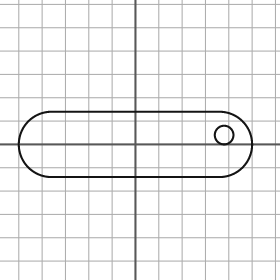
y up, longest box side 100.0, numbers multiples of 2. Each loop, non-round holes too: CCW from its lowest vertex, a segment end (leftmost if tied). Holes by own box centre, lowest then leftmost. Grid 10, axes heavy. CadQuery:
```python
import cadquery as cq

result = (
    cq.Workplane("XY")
    .moveTo(-36.0, -14.0)
    .lineTo(36.0, -14.0)
    .threePointArc((50.0, 0.0), (36.0, 14.0))
    .lineTo(-36.0, 14.0)
    .threePointArc((-50.0, 0.0), (-36.0, -14.0))
    .close()
    .moveTo(38.0, 4.0)
    .circle(4.0)
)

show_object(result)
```